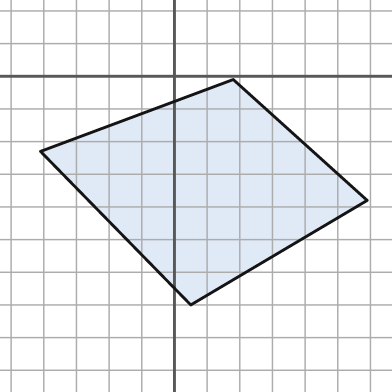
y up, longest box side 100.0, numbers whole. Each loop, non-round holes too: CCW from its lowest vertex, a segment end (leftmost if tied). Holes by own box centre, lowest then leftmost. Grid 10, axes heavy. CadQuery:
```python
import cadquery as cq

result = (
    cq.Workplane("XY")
    .moveTo(5.0, -70.0)
    .lineTo(59.0, -38.0)
    .lineTo(18.0, -1.0)
    .lineTo(-41.0, -23.0)
    .close()
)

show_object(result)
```